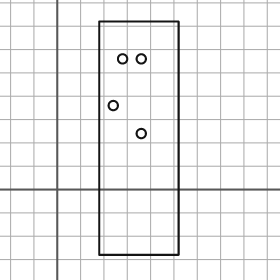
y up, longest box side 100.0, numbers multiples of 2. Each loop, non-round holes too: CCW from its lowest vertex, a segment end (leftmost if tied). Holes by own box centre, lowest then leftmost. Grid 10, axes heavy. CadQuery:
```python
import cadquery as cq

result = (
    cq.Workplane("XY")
    .moveTo(18.0, -28.0)
    .lineTo(52.0, -28.0)
    .lineTo(52.0, 72.0)
    .lineTo(18.0, 72.0)
    .close()
    .moveTo(36.0, 24.0)
    .circle(2.0)
    .moveTo(24.0, 36.0)
    .circle(2.0)
    .moveTo(28.0, 56.0)
    .circle(2.0)
    .moveTo(36.0, 56.0)
    .circle(2.0)
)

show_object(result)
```